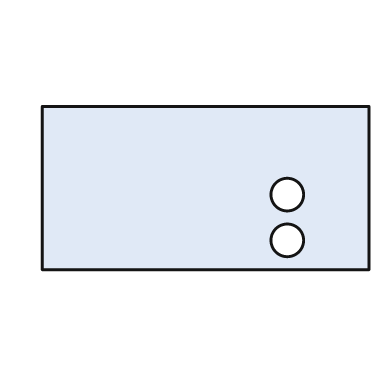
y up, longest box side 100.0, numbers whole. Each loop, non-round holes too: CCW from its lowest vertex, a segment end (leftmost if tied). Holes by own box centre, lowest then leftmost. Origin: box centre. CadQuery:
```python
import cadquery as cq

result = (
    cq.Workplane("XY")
    .moveTo(-50.0, -25.0)
    .lineTo(50.0, -25.0)
    .lineTo(50.0, 25.0)
    .lineTo(-50.0, 25.0)
    .close()
    .moveTo(25.0, -16.0)
    .circle(5.0)
    .moveTo(25.0, -2.0)
    .circle(5.0)
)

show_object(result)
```